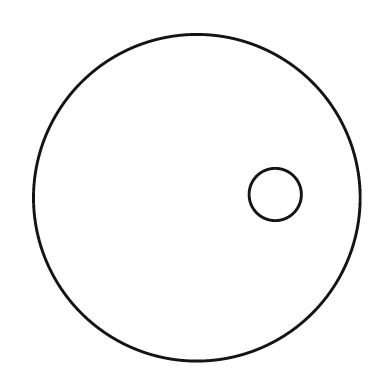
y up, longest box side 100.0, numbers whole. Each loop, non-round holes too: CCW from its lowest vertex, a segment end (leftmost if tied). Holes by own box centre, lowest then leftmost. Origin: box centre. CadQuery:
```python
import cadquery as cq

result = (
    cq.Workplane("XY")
    .moveTo(0.0, 0.0)
    .circle(50.0)
    .moveTo(24.0, 1.0)
    .circle(8.0)
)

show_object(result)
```